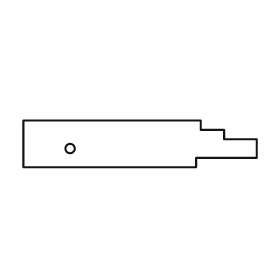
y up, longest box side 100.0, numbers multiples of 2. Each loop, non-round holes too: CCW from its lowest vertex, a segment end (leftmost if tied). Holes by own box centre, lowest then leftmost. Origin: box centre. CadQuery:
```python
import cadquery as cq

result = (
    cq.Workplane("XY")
    .moveTo(-50.0, -10.0)
    .lineTo(24.0, -10.0)
    .lineTo(24.0, -6.0)
    .lineTo(50.0, -6.0)
    .lineTo(50.0, 2.0)
    .lineTo(36.0, 2.0)
    .lineTo(36.0, 6.0)
    .lineTo(26.0, 6.0)
    .lineTo(26.0, 10.0)
    .lineTo(-50.0, 10.0)
    .close()
    .moveTo(-30.0, -2.0)
    .circle(2.0)
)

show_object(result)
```